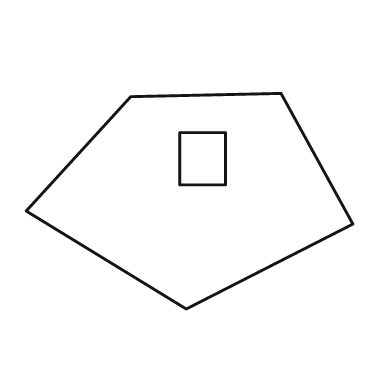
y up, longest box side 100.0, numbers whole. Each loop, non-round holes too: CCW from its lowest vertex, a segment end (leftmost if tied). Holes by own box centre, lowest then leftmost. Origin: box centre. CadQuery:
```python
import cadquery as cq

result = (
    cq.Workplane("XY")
    .moveTo(-1.0, -33.0)
    .lineTo(50.0, -7.0)
    .lineTo(28.0, 33.0)
    .lineTo(-18.0, 32.0)
    .lineTo(-50.0, -3.0)
    .close()
    .moveTo(-3.0, 5.0)
    .lineTo(11.0, 5.0)
    .lineTo(11.0, 21.0)
    .lineTo(-3.0, 21.0)
    .close()
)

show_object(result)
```